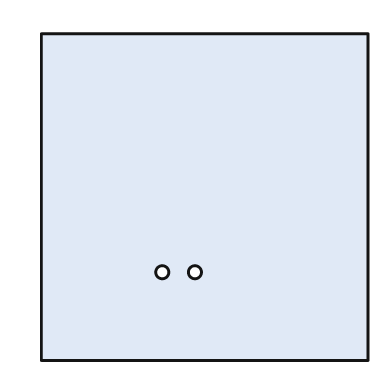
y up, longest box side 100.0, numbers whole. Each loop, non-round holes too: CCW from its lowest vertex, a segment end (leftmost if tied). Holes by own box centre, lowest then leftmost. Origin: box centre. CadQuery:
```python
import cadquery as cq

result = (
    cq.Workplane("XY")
    .moveTo(-50.0, -50.0)
    .lineTo(50.0, -50.0)
    .lineTo(50.0, 50.0)
    .lineTo(-50.0, 50.0)
    .close()
    .moveTo(-13.0, -23.0)
    .circle(2.0)
    .moveTo(-3.0, -23.0)
    .circle(2.0)
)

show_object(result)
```